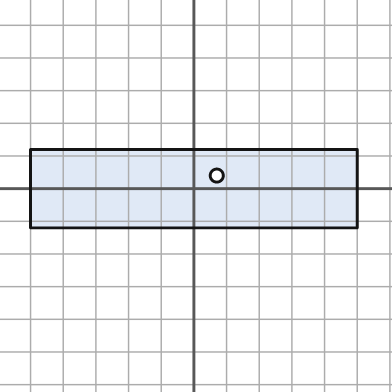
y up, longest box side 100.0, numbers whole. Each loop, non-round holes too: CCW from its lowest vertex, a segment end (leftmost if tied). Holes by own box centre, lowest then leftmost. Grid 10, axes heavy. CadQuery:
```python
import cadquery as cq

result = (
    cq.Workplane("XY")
    .moveTo(-50.0, -12.0)
    .lineTo(50.0, -12.0)
    .lineTo(50.0, 12.0)
    .lineTo(-50.0, 12.0)
    .close()
    .moveTo(7.0, 4.0)
    .circle(2.0)
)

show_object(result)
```